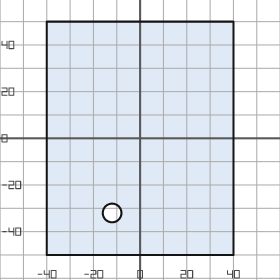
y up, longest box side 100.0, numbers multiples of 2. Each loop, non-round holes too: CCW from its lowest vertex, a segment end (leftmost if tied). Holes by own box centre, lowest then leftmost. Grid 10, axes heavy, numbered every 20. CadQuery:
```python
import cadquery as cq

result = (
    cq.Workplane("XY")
    .moveTo(-40.0, -50.0)
    .lineTo(40.0, -50.0)
    .lineTo(40.0, 50.0)
    .lineTo(-40.0, 50.0)
    .close()
    .moveTo(-12.0, -32.0)
    .circle(4.0)
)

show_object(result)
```